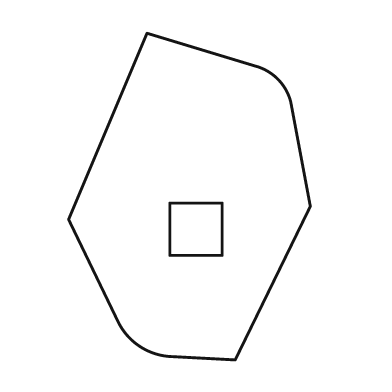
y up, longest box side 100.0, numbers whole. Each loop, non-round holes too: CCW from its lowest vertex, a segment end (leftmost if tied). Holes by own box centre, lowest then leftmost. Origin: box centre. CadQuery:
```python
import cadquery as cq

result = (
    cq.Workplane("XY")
    .moveTo(14.0, -50.0)
    .lineTo(37.0, -3.0)
    .lineTo(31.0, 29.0)
    .threePointArc((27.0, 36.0), (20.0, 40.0))
    .lineTo(-13.0, 50.0)
    .lineTo(-37.0, -7.0)
    .lineTo(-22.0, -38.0)
    .threePointArc((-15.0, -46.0), (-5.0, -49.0))
    .close()
    .moveTo(-6.0, -18.0)
    .lineTo(10.0, -18.0)
    .lineTo(10.0, -2.0)
    .lineTo(-6.0, -2.0)
    .close()
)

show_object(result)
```